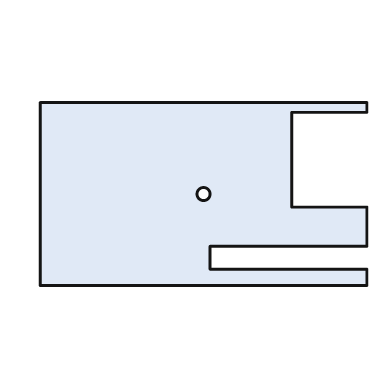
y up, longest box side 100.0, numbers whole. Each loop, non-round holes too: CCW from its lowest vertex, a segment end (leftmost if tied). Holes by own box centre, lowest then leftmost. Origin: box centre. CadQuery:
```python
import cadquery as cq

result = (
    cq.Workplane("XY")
    .moveTo(-50.0, -28.0)
    .lineTo(50.0, -28.0)
    .lineTo(50.0, -23.0)
    .lineTo(2.0, -23.0)
    .lineTo(2.0, -16.0)
    .lineTo(50.0, -16.0)
    .lineTo(50.0, -4.0)
    .lineTo(27.0, -4.0)
    .lineTo(27.0, 25.0)
    .lineTo(50.0, 25.0)
    .lineTo(50.0, 28.0)
    .lineTo(-50.0, 28.0)
    .close()
    .moveTo(0.0, 0.0)
    .circle(2.0)
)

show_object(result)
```